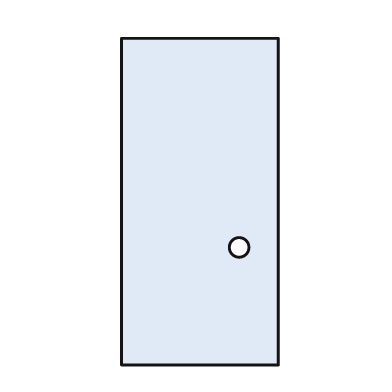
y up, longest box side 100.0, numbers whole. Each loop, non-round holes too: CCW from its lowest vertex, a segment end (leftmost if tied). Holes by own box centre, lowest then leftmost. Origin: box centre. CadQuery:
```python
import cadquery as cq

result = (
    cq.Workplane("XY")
    .moveTo(-24.0, -50.0)
    .lineTo(24.0, -50.0)
    .lineTo(24.0, 50.0)
    .lineTo(-24.0, 50.0)
    .close()
    .moveTo(12.0, -14.0)
    .circle(3.0)
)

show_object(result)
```